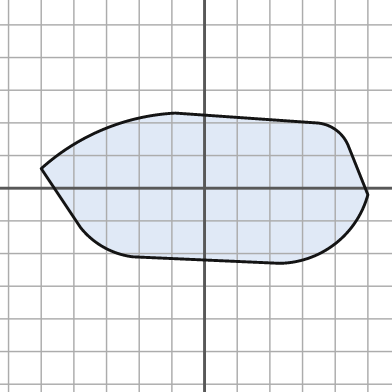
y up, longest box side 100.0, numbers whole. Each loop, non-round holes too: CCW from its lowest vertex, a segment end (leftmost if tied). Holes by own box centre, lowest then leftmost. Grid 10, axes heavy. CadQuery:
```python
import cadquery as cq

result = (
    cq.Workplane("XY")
    .moveTo(23.0, -23.0)
    .threePointArc((40.0, -17.0), (50.0, -2.0))
    .lineTo(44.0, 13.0)
    .threePointArc((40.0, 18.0), (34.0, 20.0))
    .lineTo(-9.0, 23.0)
    .threePointArc((-31.0, 18.0), (-50.0, 6.0))
    .lineTo(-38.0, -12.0)
    .threePointArc((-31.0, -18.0), (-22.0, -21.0))
    .close()
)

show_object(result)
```